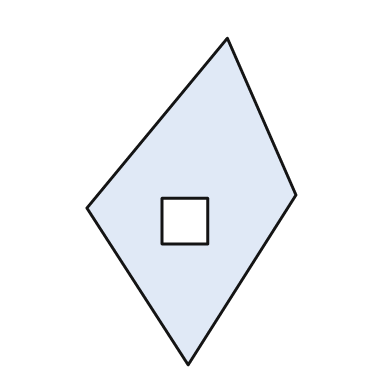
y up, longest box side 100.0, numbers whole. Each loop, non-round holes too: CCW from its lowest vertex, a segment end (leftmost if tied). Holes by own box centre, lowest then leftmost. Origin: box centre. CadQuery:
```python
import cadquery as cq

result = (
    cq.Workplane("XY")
    .moveTo(-1.0, -50.0)
    .lineTo(32.0, 2.0)
    .lineTo(11.0, 50.0)
    .lineTo(-32.0, -2.0)
    .close()
    .moveTo(-9.0, -13.0)
    .lineTo(5.0, -13.0)
    .lineTo(5.0, 1.0)
    .lineTo(-9.0, 1.0)
    .close()
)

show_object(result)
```